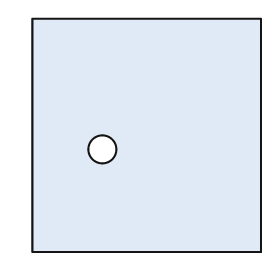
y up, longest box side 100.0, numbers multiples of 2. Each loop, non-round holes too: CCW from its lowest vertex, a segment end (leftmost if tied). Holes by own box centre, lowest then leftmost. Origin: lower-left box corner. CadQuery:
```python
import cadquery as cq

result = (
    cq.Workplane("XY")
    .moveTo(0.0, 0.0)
    .lineTo(98.0, 0.0)
    .lineTo(98.0, 100.0)
    .lineTo(0.0, 100.0)
    .close()
    .moveTo(30.0, 44.0)
    .circle(6.0)
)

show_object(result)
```